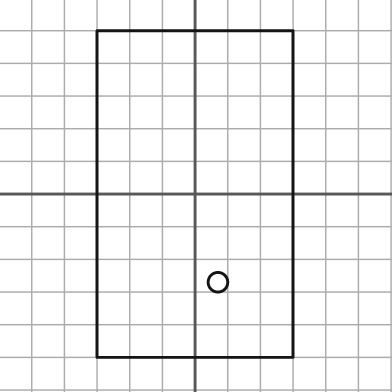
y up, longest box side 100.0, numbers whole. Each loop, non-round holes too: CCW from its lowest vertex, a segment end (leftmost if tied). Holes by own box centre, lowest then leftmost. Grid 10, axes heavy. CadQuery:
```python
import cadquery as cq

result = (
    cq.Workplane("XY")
    .moveTo(-30.0, -50.0)
    .lineTo(30.0, -50.0)
    .lineTo(30.0, 50.0)
    .lineTo(-30.0, 50.0)
    .close()
    .moveTo(7.0, -27.0)
    .circle(3.0)
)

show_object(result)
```